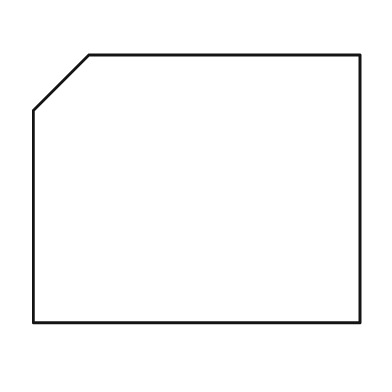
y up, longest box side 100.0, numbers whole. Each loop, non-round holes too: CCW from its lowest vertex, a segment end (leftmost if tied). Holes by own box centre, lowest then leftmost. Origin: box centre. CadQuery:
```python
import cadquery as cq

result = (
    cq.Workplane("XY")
    .moveTo(-50.0, -41.0)
    .lineTo(50.0, -41.0)
    .lineTo(50.0, 41.0)
    .lineTo(-33.0, 41.0)
    .lineTo(-50.0, 24.0)
    .close()
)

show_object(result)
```